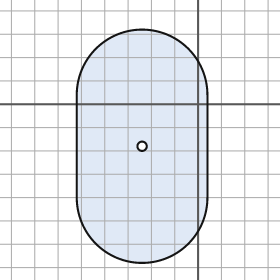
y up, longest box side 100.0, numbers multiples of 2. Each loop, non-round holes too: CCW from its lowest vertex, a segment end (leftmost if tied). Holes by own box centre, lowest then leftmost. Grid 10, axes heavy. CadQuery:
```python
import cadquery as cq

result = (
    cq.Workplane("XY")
    .moveTo(-52.0, -40.0)
    .threePointArc((-24.0, -68.0), (4.0, -40.0))
    .lineTo(4.0, 4.0)
    .threePointArc((-24.0, 32.0), (-52.0, 4.0))
    .close()
    .moveTo(-24.0, -18.0)
    .circle(2.0)
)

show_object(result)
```